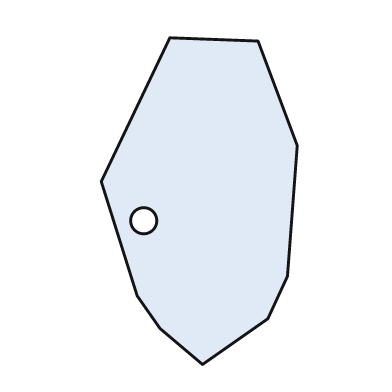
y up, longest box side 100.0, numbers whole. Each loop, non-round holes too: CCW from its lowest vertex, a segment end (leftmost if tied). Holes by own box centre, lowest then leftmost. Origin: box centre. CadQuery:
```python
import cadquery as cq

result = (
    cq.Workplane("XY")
    .moveTo(1.0, -50.0)
    .lineTo(21.0, -36.0)
    .lineTo(27.0, -23.0)
    .lineTo(30.0, 17.0)
    .lineTo(18.0, 49.0)
    .lineTo(-9.0, 50.0)
    .lineTo(-30.0, 6.0)
    .lineTo(-19.0, -29.0)
    .lineTo(-12.0, -39.0)
    .close()
    .moveTo(-17.0, -6.0)
    .circle(4.0)
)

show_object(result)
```